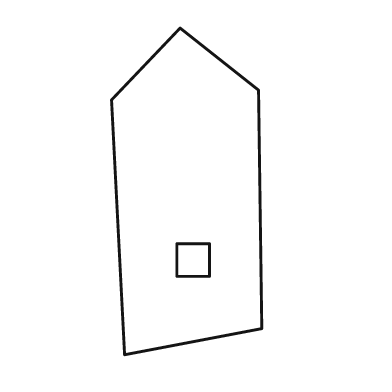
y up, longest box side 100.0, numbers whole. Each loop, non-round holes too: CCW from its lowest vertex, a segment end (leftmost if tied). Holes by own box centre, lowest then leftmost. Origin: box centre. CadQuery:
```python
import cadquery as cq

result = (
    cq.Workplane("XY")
    .moveTo(-19.0, -50.0)
    .lineTo(23.0, -42.0)
    .lineTo(22.0, 31.0)
    .lineTo(-2.0, 50.0)
    .lineTo(-23.0, 28.0)
    .close()
    .moveTo(-3.0, -26.0)
    .lineTo(7.0, -26.0)
    .lineTo(7.0, -16.0)
    .lineTo(-3.0, -16.0)
    .close()
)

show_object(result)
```